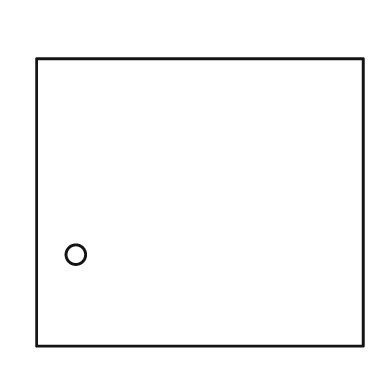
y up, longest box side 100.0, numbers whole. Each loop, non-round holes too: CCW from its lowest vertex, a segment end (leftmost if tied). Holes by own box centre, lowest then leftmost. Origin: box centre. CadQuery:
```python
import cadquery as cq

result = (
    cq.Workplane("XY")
    .moveTo(-50.0, -44.0)
    .lineTo(50.0, -44.0)
    .lineTo(50.0, 44.0)
    .lineTo(-50.0, 44.0)
    .close()
    .moveTo(-38.0, -16.0)
    .circle(3.0)
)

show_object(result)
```